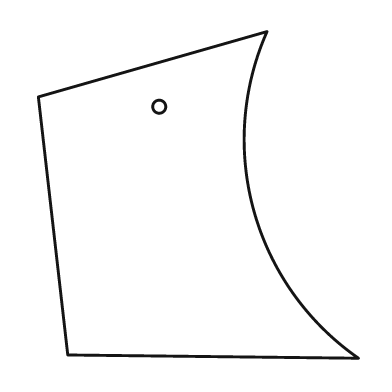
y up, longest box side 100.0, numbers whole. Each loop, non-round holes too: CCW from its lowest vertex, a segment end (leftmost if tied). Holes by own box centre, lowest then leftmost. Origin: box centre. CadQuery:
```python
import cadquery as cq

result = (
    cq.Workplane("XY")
    .moveTo(49.0, -50.0)
    .threePointArc((17.0, -5.0), (21.0, 50.0))
    .lineTo(-49.0, 30.0)
    .lineTo(-40.0, -49.0)
    .close()
    .moveTo(-12.0, 27.0)
    .circle(2.0)
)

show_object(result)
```